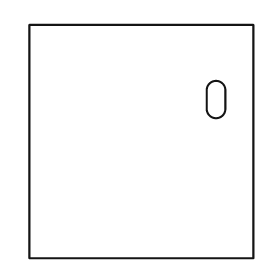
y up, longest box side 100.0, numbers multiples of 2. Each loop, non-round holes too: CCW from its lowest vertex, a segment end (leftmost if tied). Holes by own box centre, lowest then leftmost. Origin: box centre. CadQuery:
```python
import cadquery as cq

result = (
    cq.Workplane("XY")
    .moveTo(-48.0, -50.0)
    .lineTo(48.0, -50.0)
    .lineTo(48.0, 50.0)
    .lineTo(-48.0, 50.0)
    .close()
    .moveTo(28.0, 14.0)
    .threePointArc((32.0, 10.0), (36.0, 14.0))
    .lineTo(36.0, 22.0)
    .threePointArc((32.0, 26.0), (28.0, 22.0))
    .close()
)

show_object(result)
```